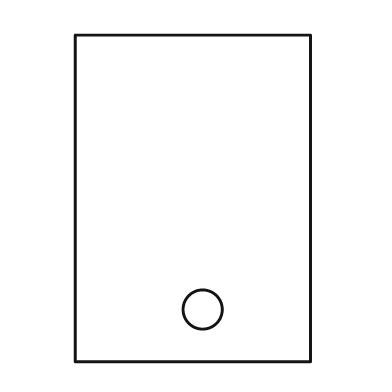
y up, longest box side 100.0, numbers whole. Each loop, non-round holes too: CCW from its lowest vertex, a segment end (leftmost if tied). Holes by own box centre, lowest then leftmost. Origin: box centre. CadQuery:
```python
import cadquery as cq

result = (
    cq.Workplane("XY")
    .moveTo(-36.0, -50.0)
    .lineTo(36.0, -50.0)
    .lineTo(36.0, 50.0)
    .lineTo(-36.0, 50.0)
    .close()
    .moveTo(3.0, -34.0)
    .circle(6.0)
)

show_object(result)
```